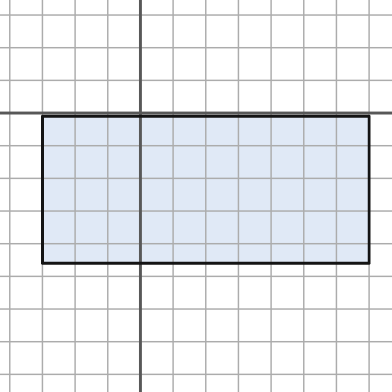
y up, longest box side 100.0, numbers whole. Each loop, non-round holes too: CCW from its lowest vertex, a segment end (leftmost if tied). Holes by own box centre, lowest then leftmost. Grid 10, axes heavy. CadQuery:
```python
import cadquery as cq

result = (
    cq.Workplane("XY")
    .moveTo(-30.0, -46.0)
    .lineTo(70.0, -46.0)
    .lineTo(70.0, -1.0)
    .lineTo(-30.0, -1.0)
    .close()
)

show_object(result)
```